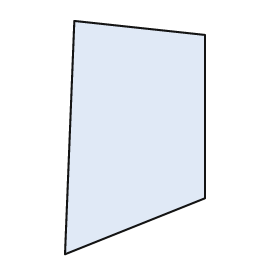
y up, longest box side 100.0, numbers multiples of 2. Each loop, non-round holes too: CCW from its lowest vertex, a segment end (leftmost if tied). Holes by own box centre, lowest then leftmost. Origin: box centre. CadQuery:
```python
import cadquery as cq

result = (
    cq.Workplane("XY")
    .moveTo(-30.0, -50.0)
    .lineTo(30.0, -26.0)
    .lineTo(30.0, 44.0)
    .lineTo(-26.0, 50.0)
    .close()
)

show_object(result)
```